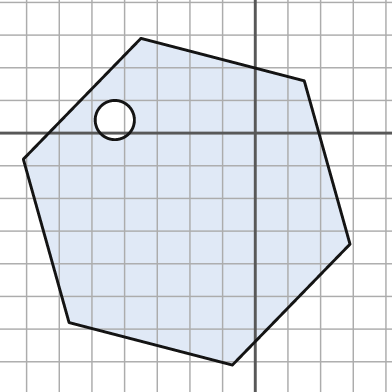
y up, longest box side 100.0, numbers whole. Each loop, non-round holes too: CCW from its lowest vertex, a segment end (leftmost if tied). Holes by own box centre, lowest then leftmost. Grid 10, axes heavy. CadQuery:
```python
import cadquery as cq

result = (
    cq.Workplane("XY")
    .moveTo(-7.0, -71.0)
    .lineTo(29.0, -34.0)
    .lineTo(15.0, 16.0)
    .lineTo(-35.0, 29.0)
    .lineTo(-71.0, -8.0)
    .lineTo(-57.0, -58.0)
    .close()
    .moveTo(-43.0, 4.0)
    .circle(6.0)
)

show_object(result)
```